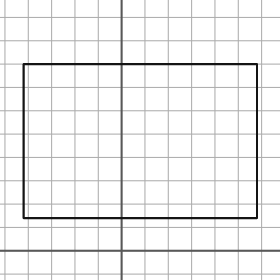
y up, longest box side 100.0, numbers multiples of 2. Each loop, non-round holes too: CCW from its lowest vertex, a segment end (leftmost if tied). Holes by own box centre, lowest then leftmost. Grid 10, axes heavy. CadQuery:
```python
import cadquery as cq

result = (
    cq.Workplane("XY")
    .moveTo(-42.0, 14.0)
    .lineTo(58.0, 14.0)
    .lineTo(58.0, 80.0)
    .lineTo(-42.0, 80.0)
    .close()
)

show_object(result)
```